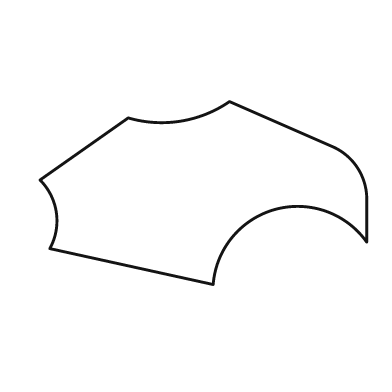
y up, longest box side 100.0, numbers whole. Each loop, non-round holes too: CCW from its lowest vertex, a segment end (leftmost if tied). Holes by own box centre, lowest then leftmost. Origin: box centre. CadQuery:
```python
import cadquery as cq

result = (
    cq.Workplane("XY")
    .moveTo(3.0, -28.0)
    .threePointArc((22.0, -5.0), (50.0, -15.0))
    .lineTo(50.0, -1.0)
    .threePointArc((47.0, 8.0), (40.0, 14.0))
    .lineTo(8.0, 28.0)
    .threePointArc((-7.0, 22.0), (-23.0, 23.0))
    .lineTo(-50.0, 4.0)
    .threePointArc((-45.0, -6.0), (-47.0, -17.0))
    .close()
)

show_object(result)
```